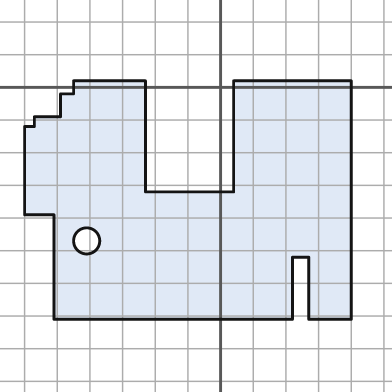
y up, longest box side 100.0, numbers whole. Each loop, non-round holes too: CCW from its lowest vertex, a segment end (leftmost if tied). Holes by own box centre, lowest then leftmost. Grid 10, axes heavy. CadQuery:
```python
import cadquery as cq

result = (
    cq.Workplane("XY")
    .moveTo(-51.0, -71.0)
    .lineTo(22.0, -71.0)
    .lineTo(22.0, -52.0)
    .lineTo(27.0, -52.0)
    .lineTo(27.0, -71.0)
    .lineTo(40.0, -71.0)
    .lineTo(40.0, 2.0)
    .lineTo(4.0, 2.0)
    .lineTo(4.0, -32.0)
    .lineTo(-23.0, -32.0)
    .lineTo(-23.0, 2.0)
    .lineTo(-45.0, 2.0)
    .lineTo(-45.0, -2.0)
    .lineTo(-49.0, -2.0)
    .lineTo(-49.0, -9.0)
    .lineTo(-57.0, -9.0)
    .lineTo(-57.0, -12.0)
    .lineTo(-60.0, -12.0)
    .lineTo(-60.0, -39.0)
    .lineTo(-51.0, -39.0)
    .close()
    .moveTo(-41.0, -47.0)
    .circle(4.0)
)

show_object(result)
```